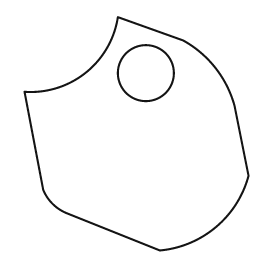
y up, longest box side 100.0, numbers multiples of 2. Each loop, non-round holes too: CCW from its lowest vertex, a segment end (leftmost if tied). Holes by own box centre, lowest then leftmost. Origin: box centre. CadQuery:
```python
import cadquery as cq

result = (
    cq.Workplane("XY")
    .moveTo(10.0, -50.0)
    .threePointArc((34.0, -40.0), (48.0, -18.0))
    .lineTo(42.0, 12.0)
    .threePointArc((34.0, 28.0), (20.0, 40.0))
    .lineTo(-8.0, 50.0)
    .threePointArc((-22.0, 26.0), (-48.0, 18.0))
    .lineTo(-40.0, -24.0)
    .threePointArc((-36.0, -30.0), (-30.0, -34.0))
    .close()
    .moveTo(4.0, 26.0)
    .circle(12.0)
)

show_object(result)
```